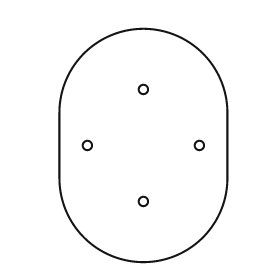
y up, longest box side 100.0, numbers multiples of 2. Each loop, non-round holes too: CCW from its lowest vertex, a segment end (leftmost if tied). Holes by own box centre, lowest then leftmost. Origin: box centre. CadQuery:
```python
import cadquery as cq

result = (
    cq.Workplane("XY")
    .moveTo(-36.0, -14.0)
    .threePointArc((0.0, -50.0), (36.0, -14.0))
    .lineTo(36.0, 14.0)
    .threePointArc((0.0, 50.0), (-36.0, 14.0))
    .close()
    .moveTo(0.0, -24.0)
    .circle(2.0)
    .moveTo(-24.0, 0.0)
    .circle(2.0)
    .moveTo(24.0, 0.0)
    .circle(2.0)
    .moveTo(0.0, 24.0)
    .circle(2.0)
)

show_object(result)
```